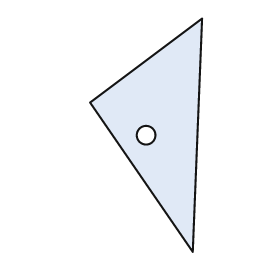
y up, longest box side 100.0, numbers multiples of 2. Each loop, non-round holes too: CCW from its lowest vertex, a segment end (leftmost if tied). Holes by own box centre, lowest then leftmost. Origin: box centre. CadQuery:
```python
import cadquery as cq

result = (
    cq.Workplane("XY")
    .moveTo(20.0, -50.0)
    .lineTo(24.0, 50.0)
    .lineTo(-24.0, 14.0)
    .close()
    .moveTo(0.0, 0.0)
    .circle(4.0)
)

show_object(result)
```